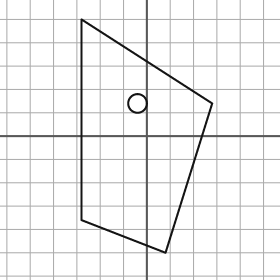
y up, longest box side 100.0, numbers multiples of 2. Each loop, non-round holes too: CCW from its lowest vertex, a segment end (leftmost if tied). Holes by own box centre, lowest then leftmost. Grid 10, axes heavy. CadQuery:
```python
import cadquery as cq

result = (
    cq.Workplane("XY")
    .moveTo(8.0, -50.0)
    .lineTo(28.0, 14.0)
    .lineTo(-28.0, 50.0)
    .lineTo(-28.0, -36.0)
    .close()
    .moveTo(-4.0, 14.0)
    .circle(4.0)
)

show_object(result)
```